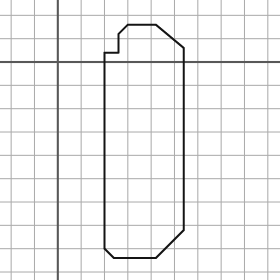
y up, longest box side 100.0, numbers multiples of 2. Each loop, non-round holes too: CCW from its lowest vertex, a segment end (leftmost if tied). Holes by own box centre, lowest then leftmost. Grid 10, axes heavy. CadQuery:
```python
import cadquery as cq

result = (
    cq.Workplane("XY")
    .moveTo(24.0, -84.0)
    .lineTo(42.0, -84.0)
    .lineTo(54.0, -72.0)
    .lineTo(54.0, 6.0)
    .lineTo(42.0, 16.0)
    .lineTo(30.0, 16.0)
    .lineTo(26.0, 12.0)
    .lineTo(26.0, 4.0)
    .lineTo(20.0, 4.0)
    .lineTo(20.0, -80.0)
    .close()
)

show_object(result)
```